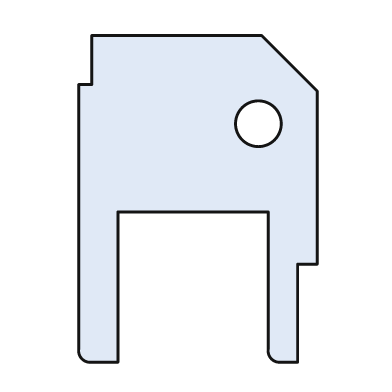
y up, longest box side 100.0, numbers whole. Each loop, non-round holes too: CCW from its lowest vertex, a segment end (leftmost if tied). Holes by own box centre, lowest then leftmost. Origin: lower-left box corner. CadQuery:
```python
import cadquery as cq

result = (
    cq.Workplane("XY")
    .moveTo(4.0, 0.0)
    .lineTo(12.0, 0.0)
    .lineTo(12.0, 46.0)
    .lineTo(58.0, 46.0)
    .lineTo(58.0, 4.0)
    .threePointArc((59.0, 1.0), (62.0, 0.0))
    .lineTo(67.0, 0.0)
    .lineTo(67.0, 30.0)
    .lineTo(73.0, 30.0)
    .lineTo(73.0, 83.0)
    .lineTo(56.0, 100.0)
    .lineTo(4.0, 100.0)
    .lineTo(4.0, 85.0)
    .lineTo(0.0, 85.0)
    .lineTo(0.0, 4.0)
    .threePointArc((1.0, 1.0), (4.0, 0.0))
    .close()
    .moveTo(55.0, 73.0)
    .circle(7.0)
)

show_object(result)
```